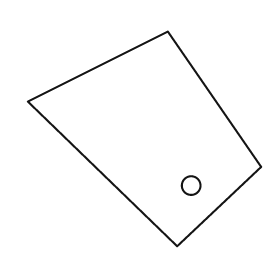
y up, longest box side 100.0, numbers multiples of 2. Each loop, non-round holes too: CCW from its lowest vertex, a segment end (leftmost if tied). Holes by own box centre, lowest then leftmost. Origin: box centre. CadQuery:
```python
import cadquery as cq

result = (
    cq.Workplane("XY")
    .moveTo(14.0, -46.0)
    .lineTo(50.0, -12.0)
    .lineTo(10.0, 46.0)
    .lineTo(-50.0, 16.0)
    .close()
    .moveTo(20.0, -20.0)
    .circle(4.0)
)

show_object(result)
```